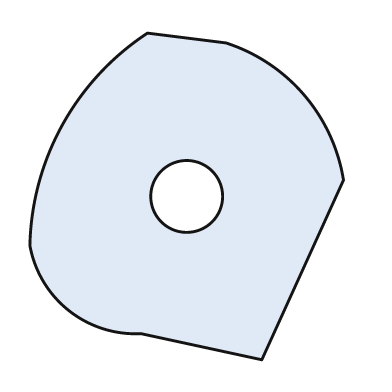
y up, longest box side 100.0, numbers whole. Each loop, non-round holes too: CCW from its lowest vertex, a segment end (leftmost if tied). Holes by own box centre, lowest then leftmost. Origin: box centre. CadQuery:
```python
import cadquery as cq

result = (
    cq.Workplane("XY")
    .moveTo(23.0, -50.0)
    .lineTo(48.0, 5.0)
    .threePointArc((36.0, 31.0), (12.0, 47.0))
    .lineTo(-12.0, 50.0)
    .threePointArc((-38.0, 22.0), (-48.0, -15.0))
    .threePointArc((-36.0, -35.0), (-14.0, -42.0))
    .close()
    .moveTo(0.0, 0.0)
    .circle(11.0)
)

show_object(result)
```